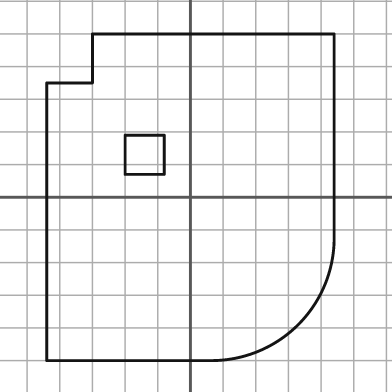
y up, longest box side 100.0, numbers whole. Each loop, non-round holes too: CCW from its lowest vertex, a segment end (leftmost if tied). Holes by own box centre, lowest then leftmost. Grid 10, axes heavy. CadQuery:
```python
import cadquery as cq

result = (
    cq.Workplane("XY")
    .moveTo(-44.0, -50.0)
    .lineTo(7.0, -50.0)
    .threePointArc((33.0, -39.0), (44.0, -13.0))
    .lineTo(44.0, 50.0)
    .lineTo(-30.0, 50.0)
    .lineTo(-30.0, 35.0)
    .lineTo(-44.0, 35.0)
    .close()
    .moveTo(-20.0, 7.0)
    .lineTo(-8.0, 7.0)
    .lineTo(-8.0, 19.0)
    .lineTo(-20.0, 19.0)
    .close()
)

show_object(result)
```